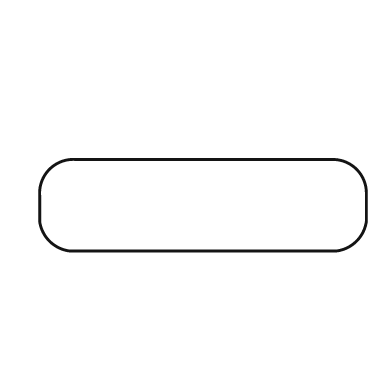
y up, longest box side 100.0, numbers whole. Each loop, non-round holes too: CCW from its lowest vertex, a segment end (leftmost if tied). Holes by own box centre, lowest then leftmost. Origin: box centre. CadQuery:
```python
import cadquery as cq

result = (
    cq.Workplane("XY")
    .moveTo(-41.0, -14.0)
    .lineTo(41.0, -14.0)
    .threePointArc((47.0, -11.0), (50.0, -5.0))
    .lineTo(50.0, 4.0)
    .threePointArc((47.0, 11.0), (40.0, 14.0))
    .lineTo(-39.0, 14.0)
    .threePointArc((-47.0, 11.0), (-50.0, 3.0))
    .lineTo(-50.0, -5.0)
    .threePointArc((-47.0, -11.0), (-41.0, -14.0))
    .close()
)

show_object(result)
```